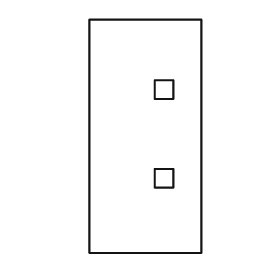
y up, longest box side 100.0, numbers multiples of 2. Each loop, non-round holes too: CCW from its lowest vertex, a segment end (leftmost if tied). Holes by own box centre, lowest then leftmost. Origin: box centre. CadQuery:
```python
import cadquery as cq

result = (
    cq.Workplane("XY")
    .moveTo(-24.0, -50.0)
    .lineTo(24.0, -50.0)
    .lineTo(24.0, 50.0)
    .lineTo(-24.0, 50.0)
    .close()
    .moveTo(4.0, -22.0)
    .lineTo(12.0, -22.0)
    .lineTo(12.0, -14.0)
    .lineTo(4.0, -14.0)
    .close()
    .moveTo(4.0, 16.0)
    .lineTo(12.0, 16.0)
    .lineTo(12.0, 24.0)
    .lineTo(4.0, 24.0)
    .close()
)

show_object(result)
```